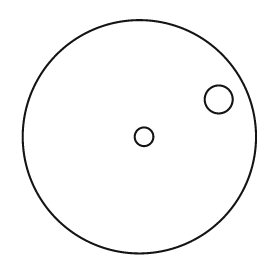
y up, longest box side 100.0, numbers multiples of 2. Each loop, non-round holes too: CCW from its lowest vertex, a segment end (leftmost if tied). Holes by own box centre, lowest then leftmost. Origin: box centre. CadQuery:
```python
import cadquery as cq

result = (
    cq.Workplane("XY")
    .moveTo(0.0, 0.0)
    .circle(50.0)
    .moveTo(2.0, 0.0)
    .circle(4.0)
    .moveTo(34.0, 16.0)
    .circle(6.0)
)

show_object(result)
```